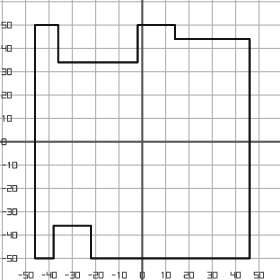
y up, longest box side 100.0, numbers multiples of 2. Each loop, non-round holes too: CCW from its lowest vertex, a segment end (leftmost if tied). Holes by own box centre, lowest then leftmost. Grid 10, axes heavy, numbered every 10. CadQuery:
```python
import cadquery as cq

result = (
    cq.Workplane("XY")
    .moveTo(-46.0, -50.0)
    .lineTo(-38.0, -50.0)
    .lineTo(-38.0, -36.0)
    .lineTo(-22.0, -36.0)
    .lineTo(-22.0, -50.0)
    .lineTo(46.0, -50.0)
    .lineTo(46.0, 44.0)
    .lineTo(14.0, 44.0)
    .lineTo(14.0, 50.0)
    .lineTo(-2.0, 50.0)
    .lineTo(-2.0, 34.0)
    .lineTo(-36.0, 34.0)
    .lineTo(-36.0, 50.0)
    .lineTo(-46.0, 50.0)
    .close()
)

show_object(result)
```